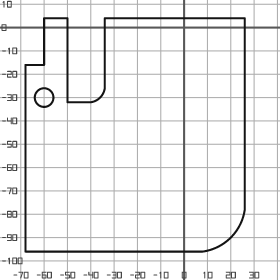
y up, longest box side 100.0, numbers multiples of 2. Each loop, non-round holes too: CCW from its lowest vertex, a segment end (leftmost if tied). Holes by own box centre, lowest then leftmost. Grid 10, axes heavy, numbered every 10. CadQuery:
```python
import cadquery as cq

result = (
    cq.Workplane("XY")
    .moveTo(-68.0, -96.0)
    .lineTo(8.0, -96.0)
    .threePointArc((20.0, -90.0), (26.0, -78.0))
    .lineTo(26.0, 4.0)
    .lineTo(-34.0, 4.0)
    .lineTo(-34.0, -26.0)
    .threePointArc((-36.0, -30.0), (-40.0, -32.0))
    .lineTo(-50.0, -32.0)
    .lineTo(-50.0, 4.0)
    .lineTo(-60.0, 4.0)
    .lineTo(-60.0, -16.0)
    .lineTo(-68.0, -16.0)
    .close()
    .moveTo(-60.0, -30.0)
    .circle(4.0)
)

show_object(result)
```